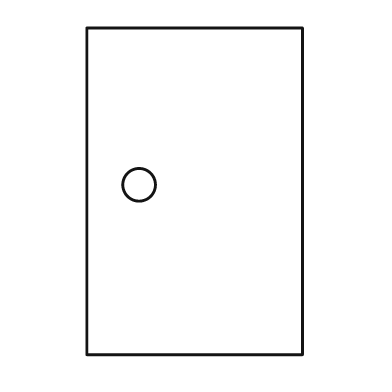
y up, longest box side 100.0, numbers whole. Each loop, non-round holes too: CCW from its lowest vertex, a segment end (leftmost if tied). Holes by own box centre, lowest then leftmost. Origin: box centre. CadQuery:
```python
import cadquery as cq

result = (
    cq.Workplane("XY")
    .moveTo(-33.0, -50.0)
    .lineTo(33.0, -50.0)
    .lineTo(33.0, 50.0)
    .lineTo(-33.0, 50.0)
    .close()
    .moveTo(-17.0, 2.0)
    .circle(5.0)
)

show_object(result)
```